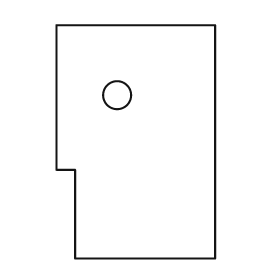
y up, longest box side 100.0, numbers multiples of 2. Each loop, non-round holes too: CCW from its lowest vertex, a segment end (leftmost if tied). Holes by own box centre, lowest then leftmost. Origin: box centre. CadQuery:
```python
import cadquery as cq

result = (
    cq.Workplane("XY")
    .moveTo(-26.0, -50.0)
    .lineTo(34.0, -50.0)
    .lineTo(34.0, 50.0)
    .lineTo(-34.0, 50.0)
    .lineTo(-34.0, -12.0)
    .lineTo(-26.0, -12.0)
    .close()
    .moveTo(-8.0, 20.0)
    .circle(6.0)
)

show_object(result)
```